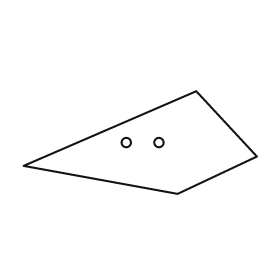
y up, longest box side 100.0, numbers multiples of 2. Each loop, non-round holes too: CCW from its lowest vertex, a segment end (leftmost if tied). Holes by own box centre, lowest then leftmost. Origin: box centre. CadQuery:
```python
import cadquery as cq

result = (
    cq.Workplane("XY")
    .moveTo(16.0, -22.0)
    .lineTo(50.0, -6.0)
    .lineTo(24.0, 22.0)
    .lineTo(-50.0, -10.0)
    .close()
    .moveTo(-6.0, 0.0)
    .circle(2.0)
    .moveTo(8.0, 0.0)
    .circle(2.0)
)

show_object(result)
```